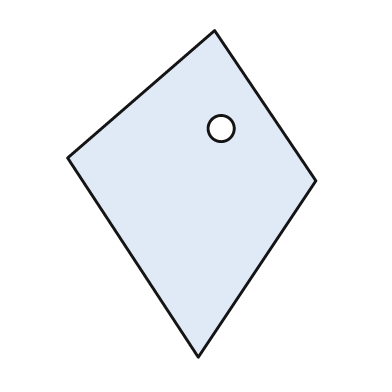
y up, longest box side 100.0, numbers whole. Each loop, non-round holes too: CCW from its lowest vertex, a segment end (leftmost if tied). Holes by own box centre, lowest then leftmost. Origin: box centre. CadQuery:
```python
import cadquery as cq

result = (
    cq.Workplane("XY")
    .moveTo(2.0, -50.0)
    .lineTo(38.0, 4.0)
    .lineTo(7.0, 50.0)
    .lineTo(-38.0, 11.0)
    .close()
    .moveTo(9.0, 20.0)
    .circle(4.0)
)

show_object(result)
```